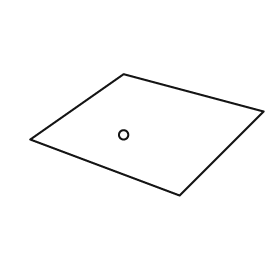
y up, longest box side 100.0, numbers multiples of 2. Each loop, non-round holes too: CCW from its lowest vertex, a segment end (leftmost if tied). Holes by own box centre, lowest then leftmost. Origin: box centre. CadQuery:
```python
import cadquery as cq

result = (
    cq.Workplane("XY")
    .moveTo(14.0, -26.0)
    .lineTo(50.0, 10.0)
    .lineTo(-10.0, 26.0)
    .lineTo(-50.0, -2.0)
    .close()
    .moveTo(-10.0, 0.0)
    .circle(2.0)
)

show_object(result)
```